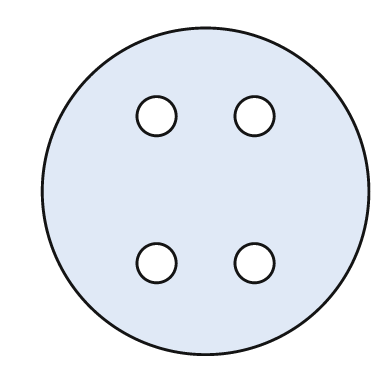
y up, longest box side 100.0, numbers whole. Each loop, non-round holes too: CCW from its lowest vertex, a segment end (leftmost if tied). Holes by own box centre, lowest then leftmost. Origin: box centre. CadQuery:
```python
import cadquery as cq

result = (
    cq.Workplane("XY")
    .moveTo(0.0, 0.0)
    .circle(50.0)
    .moveTo(-15.0, -22.0)
    .circle(6.0)
    .moveTo(15.0, -22.0)
    .circle(6.0)
    .moveTo(-15.0, 23.0)
    .circle(6.0)
    .moveTo(15.0, 23.0)
    .circle(6.0)
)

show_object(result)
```